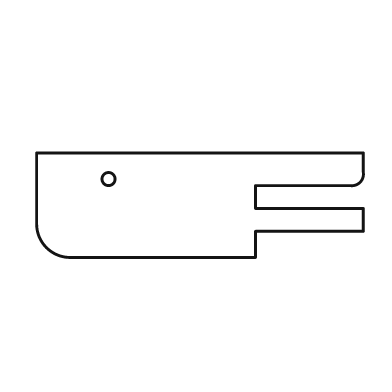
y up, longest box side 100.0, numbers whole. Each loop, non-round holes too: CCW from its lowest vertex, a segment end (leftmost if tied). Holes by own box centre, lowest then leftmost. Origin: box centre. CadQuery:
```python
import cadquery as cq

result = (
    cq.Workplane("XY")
    .moveTo(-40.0, -16.0)
    .lineTo(17.0, -16.0)
    .lineTo(17.0, -8.0)
    .lineTo(50.0, -8.0)
    .lineTo(50.0, -1.0)
    .lineTo(17.0, -1.0)
    .lineTo(17.0, 6.0)
    .lineTo(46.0, 6.0)
    .threePointArc((49.0, 7.0), (50.0, 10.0))
    .lineTo(50.0, 16.0)
    .lineTo(-50.0, 16.0)
    .lineTo(-50.0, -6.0)
    .threePointArc((-47.0, -13.0), (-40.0, -16.0))
    .close()
    .moveTo(-28.0, 8.0)
    .circle(2.0)
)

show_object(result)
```